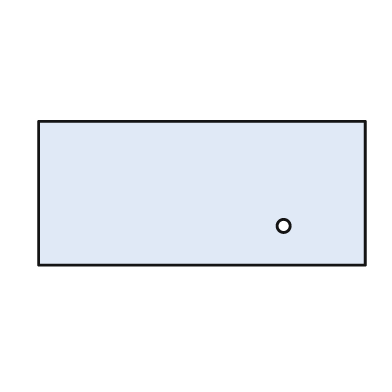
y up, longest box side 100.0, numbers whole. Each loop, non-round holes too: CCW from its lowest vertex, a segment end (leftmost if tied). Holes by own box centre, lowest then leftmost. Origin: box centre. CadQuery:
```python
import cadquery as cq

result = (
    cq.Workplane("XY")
    .moveTo(-50.0, -22.0)
    .lineTo(50.0, -22.0)
    .lineTo(50.0, 22.0)
    .lineTo(-50.0, 22.0)
    .close()
    .moveTo(25.0, -10.0)
    .circle(2.0)
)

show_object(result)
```